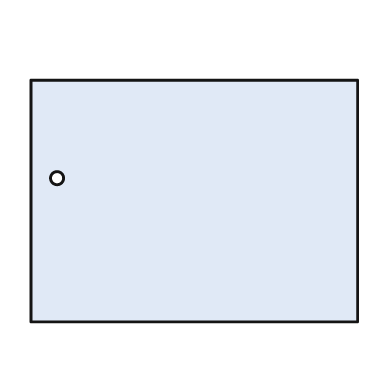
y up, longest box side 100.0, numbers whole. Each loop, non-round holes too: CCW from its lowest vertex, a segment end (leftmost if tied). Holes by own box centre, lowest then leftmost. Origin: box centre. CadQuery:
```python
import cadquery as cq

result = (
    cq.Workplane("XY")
    .moveTo(-50.0, -37.0)
    .lineTo(50.0, -37.0)
    .lineTo(50.0, 37.0)
    .lineTo(-50.0, 37.0)
    .close()
    .moveTo(-42.0, 7.0)
    .circle(2.0)
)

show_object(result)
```